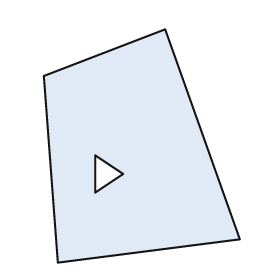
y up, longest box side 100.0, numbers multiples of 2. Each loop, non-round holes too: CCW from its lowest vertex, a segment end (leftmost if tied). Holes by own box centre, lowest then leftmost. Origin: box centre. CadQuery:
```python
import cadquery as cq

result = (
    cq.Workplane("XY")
    .moveTo(-36.0, -50.0)
    .lineTo(42.0, -40.0)
    .lineTo(10.0, 50.0)
    .lineTo(-42.0, 30.0)
    .close()
    .moveTo(-20.0, -20.0)
    .lineTo(-8.0, -12.0)
    .lineTo(-20.0, -4.0)
    .close()
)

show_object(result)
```